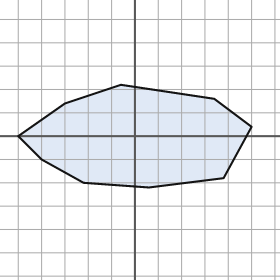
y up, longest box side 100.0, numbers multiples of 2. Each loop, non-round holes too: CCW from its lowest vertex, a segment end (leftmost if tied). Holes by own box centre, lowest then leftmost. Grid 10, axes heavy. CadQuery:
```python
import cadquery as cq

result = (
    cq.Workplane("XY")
    .moveTo(6.0, -22.0)
    .lineTo(38.0, -18.0)
    .lineTo(50.0, 4.0)
    .lineTo(34.0, 16.0)
    .lineTo(-6.0, 22.0)
    .lineTo(-30.0, 14.0)
    .lineTo(-50.0, 0.0)
    .lineTo(-40.0, -10.0)
    .lineTo(-22.0, -20.0)
    .close()
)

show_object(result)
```